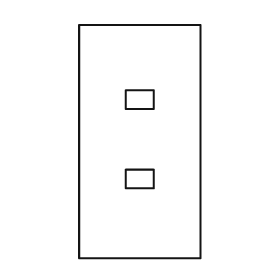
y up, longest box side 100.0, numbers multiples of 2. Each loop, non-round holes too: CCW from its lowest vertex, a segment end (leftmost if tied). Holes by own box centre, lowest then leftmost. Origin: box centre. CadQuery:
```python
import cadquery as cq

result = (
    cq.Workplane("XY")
    .moveTo(-26.0, -50.0)
    .lineTo(26.0, -50.0)
    .lineTo(26.0, 50.0)
    .lineTo(-26.0, 50.0)
    .close()
    .moveTo(-6.0, -20.0)
    .lineTo(6.0, -20.0)
    .lineTo(6.0, -12.0)
    .lineTo(-6.0, -12.0)
    .close()
    .moveTo(-6.0, 14.0)
    .lineTo(6.0, 14.0)
    .lineTo(6.0, 22.0)
    .lineTo(-6.0, 22.0)
    .close()
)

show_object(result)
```